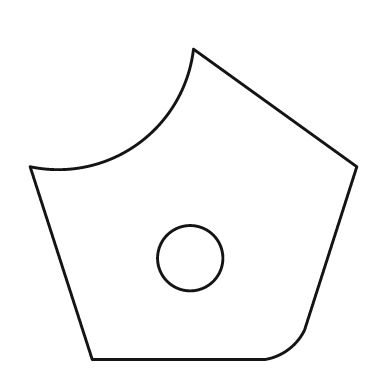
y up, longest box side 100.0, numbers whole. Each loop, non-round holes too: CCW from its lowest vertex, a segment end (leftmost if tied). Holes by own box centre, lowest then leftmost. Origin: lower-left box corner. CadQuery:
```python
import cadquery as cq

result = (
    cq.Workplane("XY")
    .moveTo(19.0, 0.0)
    .lineTo(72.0, 0.0)
    .threePointArc((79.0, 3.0), (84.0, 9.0))
    .lineTo(100.0, 59.0)
    .lineTo(50.0, 95.0)
    .threePointArc((33.0, 66.0), (0.0, 59.0))
    .close()
    .moveTo(49.0, 31.0)
    .circle(10.0)
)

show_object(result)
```